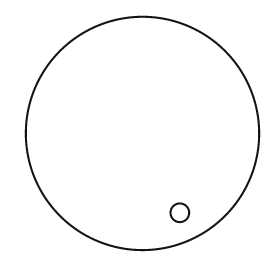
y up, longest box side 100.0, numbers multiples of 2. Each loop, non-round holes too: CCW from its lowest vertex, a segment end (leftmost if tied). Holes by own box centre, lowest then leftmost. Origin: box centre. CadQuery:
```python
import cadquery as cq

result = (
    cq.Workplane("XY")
    .moveTo(0.0, 0.0)
    .circle(50.0)
    .moveTo(16.0, -34.0)
    .circle(4.0)
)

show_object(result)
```